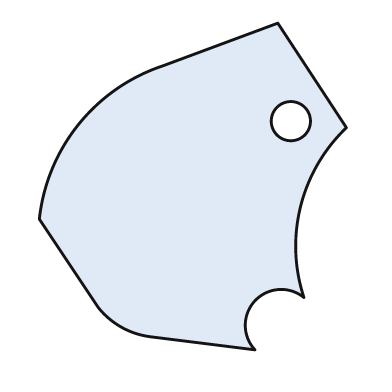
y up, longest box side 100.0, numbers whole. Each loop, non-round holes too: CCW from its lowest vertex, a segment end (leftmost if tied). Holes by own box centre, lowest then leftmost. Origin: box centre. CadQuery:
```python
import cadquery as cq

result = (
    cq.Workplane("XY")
    .moveTo(19.0, -50.0)
    .threePointArc((19.0, -35.0), (34.0, -34.0))
    .threePointArc((33.0, -6.0), (47.0, 18.0))
    .lineTo(26.0, 50.0)
    .lineTo(-9.0, 37.0)
    .threePointArc((-35.0, 19.0), (-47.0, -10.0))
    .lineTo(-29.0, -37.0)
    .threePointArc((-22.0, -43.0), (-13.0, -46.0))
    .close()
    .moveTo(30.0, 20.0)
    .circle(6.0)
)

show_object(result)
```